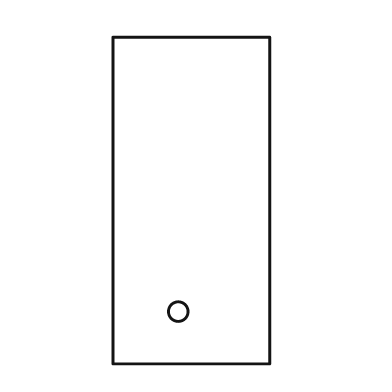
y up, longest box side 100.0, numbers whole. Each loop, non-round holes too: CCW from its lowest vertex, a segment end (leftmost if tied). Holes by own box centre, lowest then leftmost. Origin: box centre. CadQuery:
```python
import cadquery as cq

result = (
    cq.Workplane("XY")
    .moveTo(-24.0, -50.0)
    .lineTo(24.0, -50.0)
    .lineTo(24.0, 50.0)
    .lineTo(-24.0, 50.0)
    .close()
    .moveTo(-4.0, -34.0)
    .circle(3.0)
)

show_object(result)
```